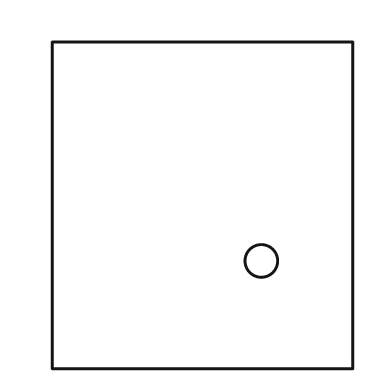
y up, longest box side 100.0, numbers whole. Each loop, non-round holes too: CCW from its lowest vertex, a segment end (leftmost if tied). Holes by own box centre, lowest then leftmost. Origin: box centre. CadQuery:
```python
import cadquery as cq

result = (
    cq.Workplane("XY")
    .moveTo(-46.0, -50.0)
    .lineTo(46.0, -50.0)
    .lineTo(46.0, 50.0)
    .lineTo(-46.0, 50.0)
    .close()
    .moveTo(18.0, -17.0)
    .circle(5.0)
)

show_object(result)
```